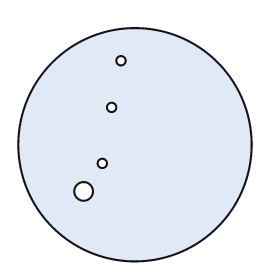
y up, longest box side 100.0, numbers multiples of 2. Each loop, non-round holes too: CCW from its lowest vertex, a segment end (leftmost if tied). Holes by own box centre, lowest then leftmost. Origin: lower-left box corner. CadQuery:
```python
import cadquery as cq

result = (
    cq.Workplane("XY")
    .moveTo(50.0, 50.0)
    .circle(50.0)
    .moveTo(28.0, 30.0)
    .circle(4.0)
    .moveTo(36.0, 42.0)
    .circle(2.0)
    .moveTo(40.0, 66.0)
    .circle(2.0)
    .moveTo(44.0, 86.0)
    .circle(2.0)
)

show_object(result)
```